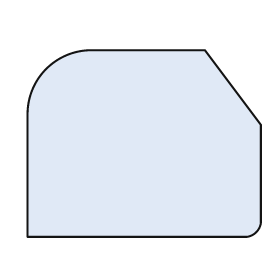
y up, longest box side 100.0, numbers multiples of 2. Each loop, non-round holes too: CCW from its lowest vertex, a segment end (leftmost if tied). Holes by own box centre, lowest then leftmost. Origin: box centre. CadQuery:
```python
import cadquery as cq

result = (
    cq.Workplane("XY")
    .moveTo(-50.0, -40.0)
    .lineTo(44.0, -40.0)
    .threePointArc((48.0, -38.0), (50.0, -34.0))
    .lineTo(50.0, 8.0)
    .lineTo(26.0, 40.0)
    .lineTo(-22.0, 40.0)
    .threePointArc((-42.0, 32.0), (-50.0, 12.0))
    .close()
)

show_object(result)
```